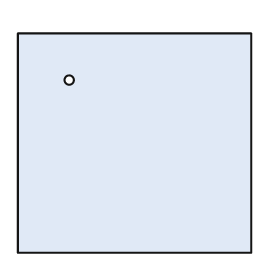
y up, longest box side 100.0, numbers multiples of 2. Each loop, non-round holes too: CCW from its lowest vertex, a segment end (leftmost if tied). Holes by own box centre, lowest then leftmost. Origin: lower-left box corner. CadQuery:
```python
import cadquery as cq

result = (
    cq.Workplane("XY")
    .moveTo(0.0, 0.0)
    .lineTo(100.0, 0.0)
    .lineTo(100.0, 94.0)
    .lineTo(0.0, 94.0)
    .close()
    .moveTo(22.0, 74.0)
    .circle(2.0)
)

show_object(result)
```